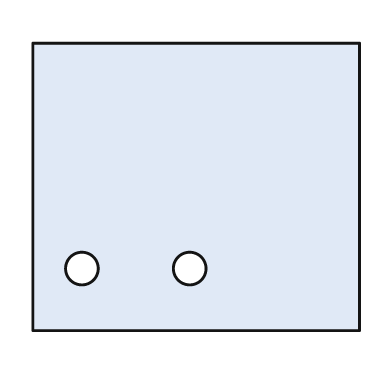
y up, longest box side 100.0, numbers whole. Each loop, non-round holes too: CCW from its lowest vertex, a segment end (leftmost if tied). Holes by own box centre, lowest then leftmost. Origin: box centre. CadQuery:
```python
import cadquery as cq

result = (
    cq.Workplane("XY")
    .moveTo(-50.0, -44.0)
    .lineTo(50.0, -44.0)
    .lineTo(50.0, 44.0)
    .lineTo(-50.0, 44.0)
    .close()
    .moveTo(-35.0, -25.0)
    .circle(5.0)
    .moveTo(-2.0, -25.0)
    .circle(5.0)
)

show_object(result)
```